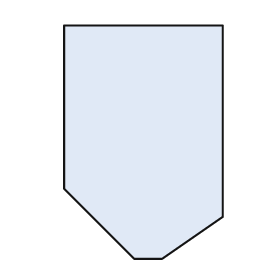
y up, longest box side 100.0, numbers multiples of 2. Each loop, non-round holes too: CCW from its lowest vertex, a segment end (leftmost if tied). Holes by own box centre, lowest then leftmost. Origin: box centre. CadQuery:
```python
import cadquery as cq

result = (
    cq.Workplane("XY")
    .moveTo(-4.0, -50.0)
    .lineTo(8.0, -50.0)
    .lineTo(34.0, -32.0)
    .lineTo(34.0, 50.0)
    .lineTo(-34.0, 50.0)
    .lineTo(-34.0, -20.0)
    .close()
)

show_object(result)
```